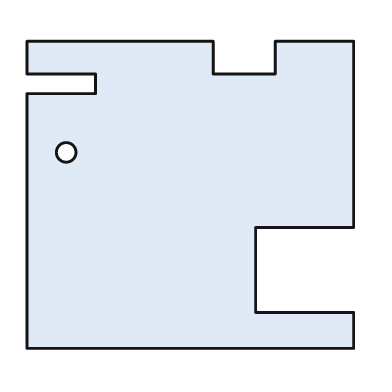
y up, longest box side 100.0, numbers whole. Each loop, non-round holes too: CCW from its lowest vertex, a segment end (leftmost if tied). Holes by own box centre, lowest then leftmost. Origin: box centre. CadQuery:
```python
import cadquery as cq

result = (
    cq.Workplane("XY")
    .moveTo(-50.0, -47.0)
    .lineTo(50.0, -47.0)
    .lineTo(50.0, -36.0)
    .lineTo(20.0, -36.0)
    .lineTo(20.0, -10.0)
    .lineTo(50.0, -10.0)
    .lineTo(50.0, 47.0)
    .lineTo(26.0, 47.0)
    .lineTo(26.0, 37.0)
    .lineTo(7.0, 37.0)
    .lineTo(7.0, 47.0)
    .lineTo(-50.0, 47.0)
    .lineTo(-50.0, 37.0)
    .lineTo(-29.0, 37.0)
    .lineTo(-29.0, 31.0)
    .lineTo(-50.0, 31.0)
    .close()
    .moveTo(-38.0, 13.0)
    .circle(3.0)
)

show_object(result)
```